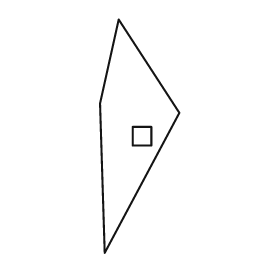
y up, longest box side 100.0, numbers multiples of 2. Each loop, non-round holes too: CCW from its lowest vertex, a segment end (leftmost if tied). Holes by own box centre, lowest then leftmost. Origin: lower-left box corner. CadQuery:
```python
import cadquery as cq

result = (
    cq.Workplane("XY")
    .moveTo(2.0, 0.0)
    .lineTo(34.0, 60.0)
    .lineTo(8.0, 100.0)
    .lineTo(0.0, 64.0)
    .close()
    .moveTo(14.0, 46.0)
    .lineTo(22.0, 46.0)
    .lineTo(22.0, 54.0)
    .lineTo(14.0, 54.0)
    .close()
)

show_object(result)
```